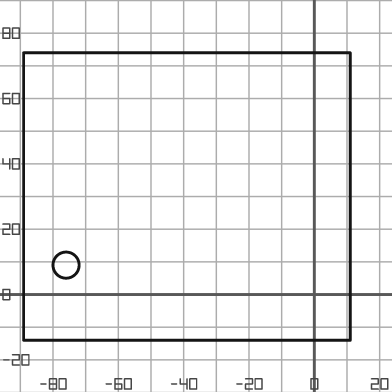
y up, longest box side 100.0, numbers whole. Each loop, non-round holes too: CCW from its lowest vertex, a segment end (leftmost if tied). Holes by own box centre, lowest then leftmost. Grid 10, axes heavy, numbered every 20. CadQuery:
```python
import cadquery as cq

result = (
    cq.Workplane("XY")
    .moveTo(-89.0, -14.0)
    .lineTo(11.0, -14.0)
    .lineTo(11.0, 74.0)
    .lineTo(-89.0, 74.0)
    .close()
    .moveTo(-76.0, 9.0)
    .circle(4.0)
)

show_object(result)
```